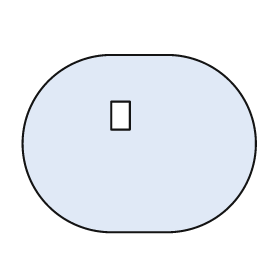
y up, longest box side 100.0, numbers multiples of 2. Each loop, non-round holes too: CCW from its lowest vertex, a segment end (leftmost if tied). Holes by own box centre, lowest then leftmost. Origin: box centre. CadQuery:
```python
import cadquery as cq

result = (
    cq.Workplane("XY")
    .moveTo(-12.0, -38.0)
    .lineTo(12.0, -38.0)
    .threePointArc((50.0, 0.0), (12.0, 38.0))
    .lineTo(-12.0, 38.0)
    .threePointArc((-50.0, 0.0), (-12.0, -38.0))
    .close()
    .moveTo(-12.0, 6.0)
    .lineTo(-4.0, 6.0)
    .lineTo(-4.0, 18.0)
    .lineTo(-12.0, 18.0)
    .close()
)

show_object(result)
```